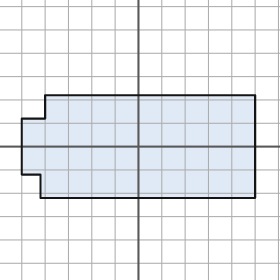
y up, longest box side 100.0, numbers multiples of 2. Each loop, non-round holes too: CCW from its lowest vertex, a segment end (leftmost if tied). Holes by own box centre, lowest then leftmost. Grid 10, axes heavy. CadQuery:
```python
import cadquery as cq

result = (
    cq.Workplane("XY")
    .moveTo(-42.0, -22.0)
    .lineTo(50.0, -22.0)
    .lineTo(50.0, 22.0)
    .lineTo(-40.0, 22.0)
    .lineTo(-40.0, 12.0)
    .lineTo(-50.0, 12.0)
    .lineTo(-50.0, -12.0)
    .lineTo(-42.0, -12.0)
    .close()
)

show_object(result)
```